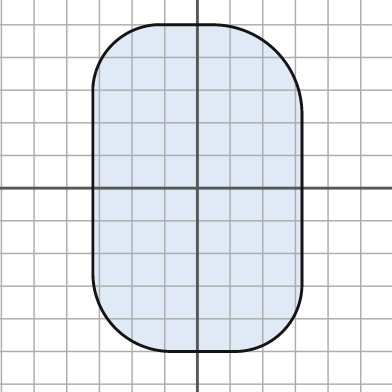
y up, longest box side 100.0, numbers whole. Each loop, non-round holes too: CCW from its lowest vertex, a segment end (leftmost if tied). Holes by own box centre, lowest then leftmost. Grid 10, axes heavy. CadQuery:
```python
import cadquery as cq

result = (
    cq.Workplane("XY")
    .moveTo(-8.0, -50.0)
    .lineTo(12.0, -50.0)
    .threePointArc((26.0, -44.0), (32.0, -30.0))
    .lineTo(32.0, 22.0)
    .threePointArc((24.0, 42.0), (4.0, 50.0))
    .lineTo(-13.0, 50.0)
    .threePointArc((-26.0, 44.0), (-32.0, 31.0))
    .lineTo(-32.0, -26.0)
    .threePointArc((-25.0, -43.0), (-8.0, -50.0))
    .close()
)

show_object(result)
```